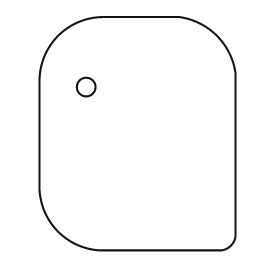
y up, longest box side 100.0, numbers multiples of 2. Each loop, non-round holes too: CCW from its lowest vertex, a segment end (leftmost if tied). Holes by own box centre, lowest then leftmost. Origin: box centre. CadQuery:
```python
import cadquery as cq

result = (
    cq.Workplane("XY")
    .moveTo(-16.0, -50.0)
    .lineTo(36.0, -50.0)
    .threePointArc((40.0, -48.0), (42.0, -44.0))
    .lineTo(42.0, 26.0)
    .threePointArc((34.0, 42.0), (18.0, 50.0))
    .lineTo(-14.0, 50.0)
    .threePointArc((-34.0, 42.0), (-42.0, 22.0))
    .lineTo(-42.0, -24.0)
    .threePointArc((-34.0, -42.0), (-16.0, -50.0))
    .close()
    .moveTo(-22.0, 20.0)
    .circle(4.0)
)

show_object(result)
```